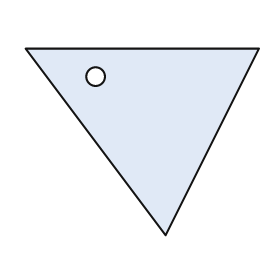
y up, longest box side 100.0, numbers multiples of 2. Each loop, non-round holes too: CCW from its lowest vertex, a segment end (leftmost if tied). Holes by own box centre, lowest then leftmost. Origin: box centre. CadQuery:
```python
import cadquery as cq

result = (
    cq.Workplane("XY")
    .moveTo(10.0, -40.0)
    .lineTo(50.0, 40.0)
    .lineTo(-50.0, 40.0)
    .close()
    .moveTo(-20.0, 28.0)
    .circle(4.0)
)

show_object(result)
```